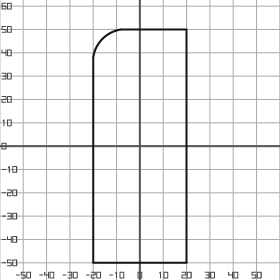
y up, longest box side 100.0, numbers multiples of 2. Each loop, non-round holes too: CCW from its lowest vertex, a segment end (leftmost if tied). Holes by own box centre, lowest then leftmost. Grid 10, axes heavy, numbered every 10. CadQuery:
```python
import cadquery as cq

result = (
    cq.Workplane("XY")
    .moveTo(-20.0, -50.0)
    .lineTo(20.0, -50.0)
    .lineTo(20.0, 50.0)
    .lineTo(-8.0, 50.0)
    .threePointArc((-16.0, 46.0), (-20.0, 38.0))
    .close()
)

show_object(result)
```